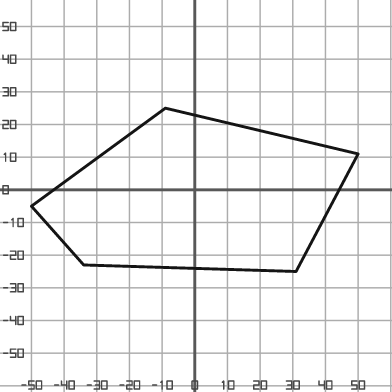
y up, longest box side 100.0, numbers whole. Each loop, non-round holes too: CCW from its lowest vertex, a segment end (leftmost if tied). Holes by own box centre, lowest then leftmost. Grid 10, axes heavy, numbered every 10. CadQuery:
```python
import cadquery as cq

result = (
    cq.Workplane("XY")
    .moveTo(31.0, -25.0)
    .lineTo(50.0, 11.0)
    .lineTo(-9.0, 25.0)
    .lineTo(-50.0, -5.0)
    .lineTo(-34.0, -23.0)
    .close()
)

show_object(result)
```